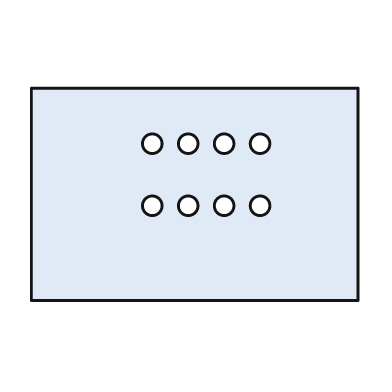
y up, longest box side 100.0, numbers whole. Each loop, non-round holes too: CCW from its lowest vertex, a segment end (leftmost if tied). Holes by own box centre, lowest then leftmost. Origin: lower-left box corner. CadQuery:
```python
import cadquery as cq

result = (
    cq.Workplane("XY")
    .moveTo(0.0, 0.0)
    .lineTo(100.0, 0.0)
    .lineTo(100.0, 65.0)
    .lineTo(0.0, 65.0)
    .close()
    .moveTo(37.0, 29.0)
    .circle(3.0)
    .moveTo(48.0, 29.0)
    .circle(3.0)
    .moveTo(59.0, 29.0)
    .circle(3.0)
    .moveTo(70.0, 29.0)
    .circle(3.0)
    .moveTo(37.0, 48.0)
    .circle(3.0)
    .moveTo(48.0, 48.0)
    .circle(3.0)
    .moveTo(59.0, 48.0)
    .circle(3.0)
    .moveTo(70.0, 48.0)
    .circle(3.0)
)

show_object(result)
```